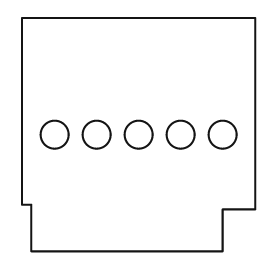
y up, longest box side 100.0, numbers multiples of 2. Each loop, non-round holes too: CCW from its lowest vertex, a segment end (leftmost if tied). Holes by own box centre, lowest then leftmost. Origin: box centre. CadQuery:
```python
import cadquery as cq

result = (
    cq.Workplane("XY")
    .moveTo(-46.0, -50.0)
    .lineTo(36.0, -50.0)
    .lineTo(36.0, -32.0)
    .lineTo(50.0, -32.0)
    .lineTo(50.0, 50.0)
    .lineTo(-50.0, 50.0)
    .lineTo(-50.0, -30.0)
    .lineTo(-46.0, -30.0)
    .close()
    .moveTo(-36.0, 0.0)
    .circle(6.0)
    .moveTo(-18.0, 0.0)
    .circle(6.0)
    .moveTo(0.0, 0.0)
    .circle(6.0)
    .moveTo(18.0, 0.0)
    .circle(6.0)
    .moveTo(36.0, 0.0)
    .circle(6.0)
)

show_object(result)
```